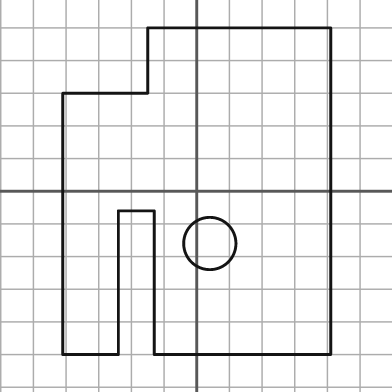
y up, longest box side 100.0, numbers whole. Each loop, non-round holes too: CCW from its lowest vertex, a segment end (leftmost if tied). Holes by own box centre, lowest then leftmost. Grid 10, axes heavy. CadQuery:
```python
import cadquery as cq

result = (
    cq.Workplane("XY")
    .moveTo(-41.0, -50.0)
    .lineTo(-24.0, -50.0)
    .lineTo(-24.0, -6.0)
    .lineTo(-13.0, -6.0)
    .lineTo(-13.0, -50.0)
    .lineTo(41.0, -50.0)
    .lineTo(41.0, 50.0)
    .lineTo(-15.0, 50.0)
    .lineTo(-15.0, 30.0)
    .lineTo(-41.0, 30.0)
    .close()
    .moveTo(4.0, -16.0)
    .circle(8.0)
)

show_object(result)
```